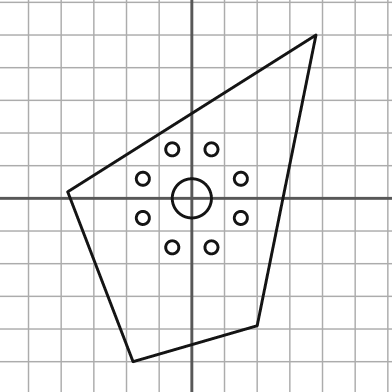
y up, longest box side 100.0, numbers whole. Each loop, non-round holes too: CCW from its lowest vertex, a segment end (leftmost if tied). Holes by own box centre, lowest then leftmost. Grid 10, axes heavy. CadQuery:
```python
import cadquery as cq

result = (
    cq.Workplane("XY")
    .moveTo(-18.0, -50.0)
    .lineTo(20.0, -39.0)
    .lineTo(38.0, 50.0)
    .lineTo(-38.0, 2.0)
    .close()
    .moveTo(-6.0, -15.0)
    .circle(2.0)
    .moveTo(6.0, -15.0)
    .circle(2.0)
    .moveTo(-15.0, -6.0)
    .circle(2.0)
    .moveTo(15.0, -6.0)
    .circle(2.0)
    .moveTo(0.0, 0.0)
    .circle(6.0)
    .moveTo(-15.0, 6.0)
    .circle(2.0)
    .moveTo(15.0, 6.0)
    .circle(2.0)
    .moveTo(-6.0, 15.0)
    .circle(2.0)
    .moveTo(6.0, 15.0)
    .circle(2.0)
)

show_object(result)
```